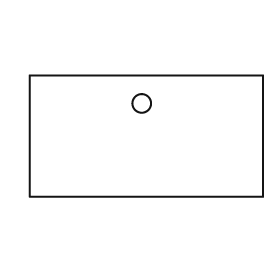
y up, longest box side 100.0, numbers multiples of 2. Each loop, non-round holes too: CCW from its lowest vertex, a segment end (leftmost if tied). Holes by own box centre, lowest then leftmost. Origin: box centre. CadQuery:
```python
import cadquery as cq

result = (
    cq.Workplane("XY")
    .moveTo(-50.0, -26.0)
    .lineTo(50.0, -26.0)
    .lineTo(50.0, 26.0)
    .lineTo(-50.0, 26.0)
    .close()
    .moveTo(-2.0, 14.0)
    .circle(4.0)
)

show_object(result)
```